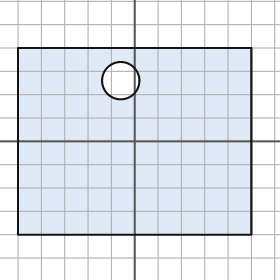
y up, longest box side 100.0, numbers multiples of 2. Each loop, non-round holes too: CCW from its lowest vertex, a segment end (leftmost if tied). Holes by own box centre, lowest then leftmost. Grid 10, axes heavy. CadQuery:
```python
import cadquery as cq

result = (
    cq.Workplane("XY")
    .moveTo(-50.0, -40.0)
    .lineTo(50.0, -40.0)
    .lineTo(50.0, 40.0)
    .lineTo(-50.0, 40.0)
    .close()
    .moveTo(-6.0, 26.0)
    .circle(8.0)
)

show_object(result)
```